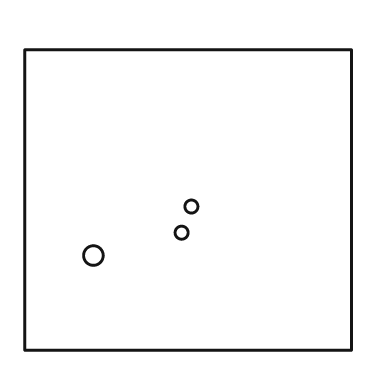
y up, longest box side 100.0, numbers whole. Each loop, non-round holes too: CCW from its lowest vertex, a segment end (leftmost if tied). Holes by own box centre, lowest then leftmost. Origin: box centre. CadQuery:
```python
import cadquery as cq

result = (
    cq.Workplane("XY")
    .moveTo(-50.0, -46.0)
    .lineTo(50.0, -46.0)
    .lineTo(50.0, 46.0)
    .lineTo(-50.0, 46.0)
    .close()
    .moveTo(-29.0, -17.0)
    .circle(3.0)
    .moveTo(-2.0, -10.0)
    .circle(2.0)
    .moveTo(1.0, -2.0)
    .circle(2.0)
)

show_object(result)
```